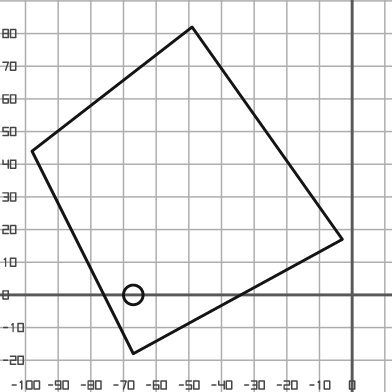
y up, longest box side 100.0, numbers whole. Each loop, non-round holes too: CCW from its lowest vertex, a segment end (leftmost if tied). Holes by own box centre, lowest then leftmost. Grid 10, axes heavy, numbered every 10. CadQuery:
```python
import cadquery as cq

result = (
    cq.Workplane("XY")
    .moveTo(-67.0, -18.0)
    .lineTo(-3.0, 17.0)
    .lineTo(-49.0, 82.0)
    .lineTo(-98.0, 44.0)
    .close()
    .moveTo(-67.0, 0.0)
    .circle(3.0)
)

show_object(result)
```